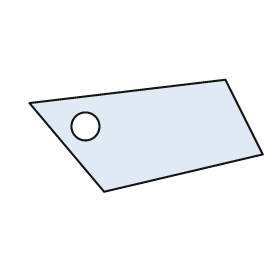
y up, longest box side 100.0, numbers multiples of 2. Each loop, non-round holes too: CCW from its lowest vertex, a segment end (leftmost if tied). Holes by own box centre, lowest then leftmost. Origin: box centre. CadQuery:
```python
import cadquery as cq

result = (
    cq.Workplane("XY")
    .moveTo(-18.0, -24.0)
    .lineTo(50.0, -8.0)
    .lineTo(34.0, 24.0)
    .lineTo(-50.0, 14.0)
    .close()
    .moveTo(-26.0, 4.0)
    .circle(6.0)
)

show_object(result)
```